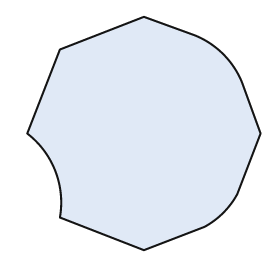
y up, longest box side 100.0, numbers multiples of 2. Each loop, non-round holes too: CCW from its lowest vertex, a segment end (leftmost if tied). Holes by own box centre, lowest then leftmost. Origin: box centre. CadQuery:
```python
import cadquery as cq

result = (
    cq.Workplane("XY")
    .moveTo(0.0, -50.0)
    .lineTo(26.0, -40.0)
    .threePointArc((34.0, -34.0), (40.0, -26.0))
    .lineTo(50.0, 0.0)
    .lineTo(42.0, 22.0)
    .threePointArc((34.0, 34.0), (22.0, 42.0))
    .lineTo(0.0, 50.0)
    .lineTo(-36.0, 36.0)
    .lineTo(-50.0, 0.0)
    .threePointArc((-38.0, -16.0), (-36.0, -36.0))
    .close()
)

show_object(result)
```